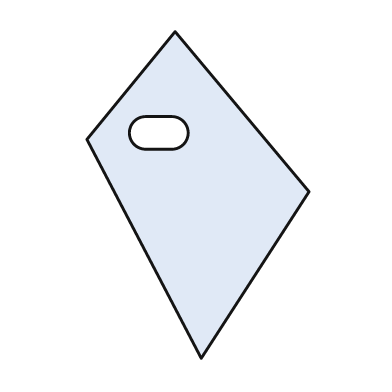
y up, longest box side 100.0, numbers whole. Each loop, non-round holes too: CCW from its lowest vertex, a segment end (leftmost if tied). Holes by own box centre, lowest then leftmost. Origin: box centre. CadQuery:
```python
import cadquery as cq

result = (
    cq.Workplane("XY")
    .moveTo(1.0, -50.0)
    .lineTo(34.0, 1.0)
    .lineTo(-7.0, 50.0)
    .lineTo(-34.0, 17.0)
    .close()
    .moveTo(-16.0, 14.0)
    .lineTo(-8.0, 14.0)
    .threePointArc((-3.0, 19.0), (-8.0, 24.0))
    .lineTo(-16.0, 24.0)
    .threePointArc((-21.0, 19.0), (-16.0, 14.0))
    .close()
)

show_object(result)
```